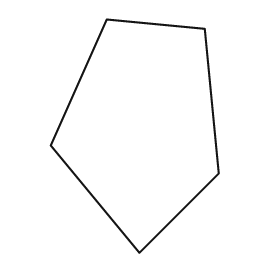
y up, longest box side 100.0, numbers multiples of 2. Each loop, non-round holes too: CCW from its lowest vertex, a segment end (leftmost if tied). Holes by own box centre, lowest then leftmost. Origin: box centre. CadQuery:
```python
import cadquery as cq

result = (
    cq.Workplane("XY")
    .moveTo(2.0, -50.0)
    .lineTo(36.0, -16.0)
    .lineTo(30.0, 46.0)
    .lineTo(-12.0, 50.0)
    .lineTo(-36.0, -4.0)
    .close()
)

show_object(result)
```